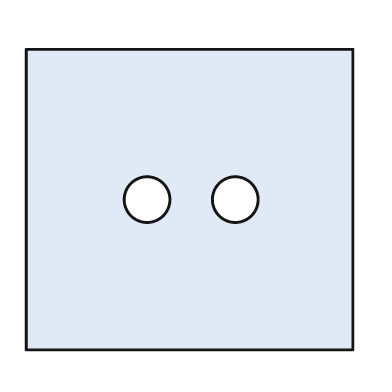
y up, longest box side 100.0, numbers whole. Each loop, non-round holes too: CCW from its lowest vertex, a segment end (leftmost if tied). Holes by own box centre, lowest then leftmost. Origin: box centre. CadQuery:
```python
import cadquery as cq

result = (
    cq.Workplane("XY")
    .moveTo(-50.0, -46.0)
    .lineTo(50.0, -46.0)
    .lineTo(50.0, 46.0)
    .lineTo(-50.0, 46.0)
    .close()
    .moveTo(-13.0, 0.0)
    .circle(7.0)
    .moveTo(14.0, 0.0)
    .circle(7.0)
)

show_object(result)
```